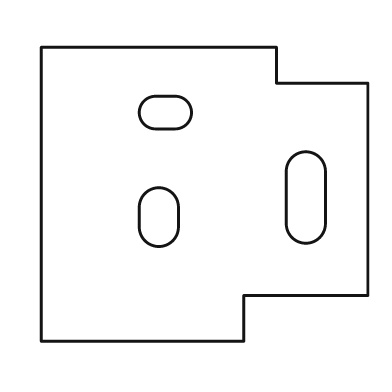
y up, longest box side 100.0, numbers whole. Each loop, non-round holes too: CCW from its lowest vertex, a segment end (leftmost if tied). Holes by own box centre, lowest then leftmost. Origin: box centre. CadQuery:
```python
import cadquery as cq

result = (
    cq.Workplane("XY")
    .moveTo(-50.0, -45.0)
    .lineTo(12.0, -45.0)
    .lineTo(12.0, -31.0)
    .lineTo(50.0, -31.0)
    .lineTo(50.0, 34.0)
    .lineTo(22.0, 34.0)
    .lineTo(22.0, 45.0)
    .lineTo(-50.0, 45.0)
    .close()
    .moveTo(-20.0, -10.0)
    .threePointArc((-14.0, -16.0), (-8.0, -10.0))
    .lineTo(-8.0, -4.0)
    .threePointArc((-14.0, 2.0), (-20.0, -4.0))
    .close()
    .moveTo(25.0, -9.0)
    .threePointArc((31.0, -15.0), (37.0, -9.0))
    .lineTo(37.0, 7.0)
    .threePointArc((31.0, 13.0), (25.0, 7.0))
    .close()
    .moveTo(-15.0, 20.0)
    .lineTo(-9.0, 20.0)
    .threePointArc((-4.0, 25.0), (-9.0, 30.0))
    .lineTo(-15.0, 30.0)
    .threePointArc((-20.0, 25.0), (-15.0, 20.0))
    .close()
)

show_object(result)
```